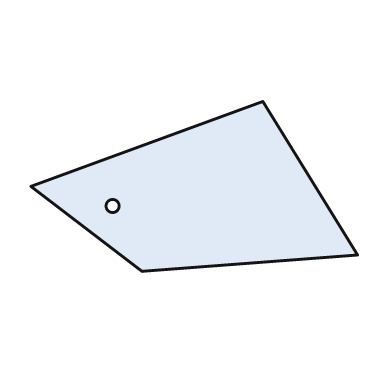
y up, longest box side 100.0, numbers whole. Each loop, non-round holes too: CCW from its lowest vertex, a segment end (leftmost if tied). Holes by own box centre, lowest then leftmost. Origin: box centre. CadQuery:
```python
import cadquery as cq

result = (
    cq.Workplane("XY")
    .moveTo(-16.0, -26.0)
    .lineTo(50.0, -21.0)
    .lineTo(21.0, 26.0)
    .lineTo(-50.0, 0.0)
    .close()
    .moveTo(-25.0, -6.0)
    .circle(2.0)
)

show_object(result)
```